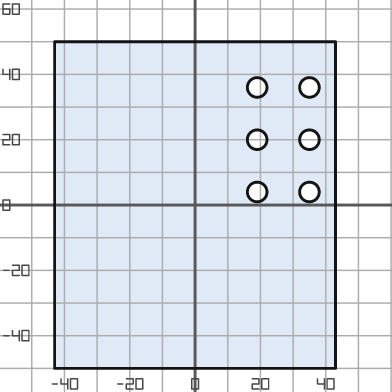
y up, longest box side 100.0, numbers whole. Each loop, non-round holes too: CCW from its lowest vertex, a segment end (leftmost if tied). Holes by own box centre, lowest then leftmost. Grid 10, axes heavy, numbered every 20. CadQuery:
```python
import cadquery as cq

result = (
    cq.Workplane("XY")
    .moveTo(-43.0, -50.0)
    .lineTo(43.0, -50.0)
    .lineTo(43.0, 50.0)
    .lineTo(-43.0, 50.0)
    .close()
    .moveTo(19.0, 4.0)
    .circle(3.0)
    .moveTo(35.0, 4.0)
    .circle(3.0)
    .moveTo(19.0, 20.0)
    .circle(3.0)
    .moveTo(35.0, 20.0)
    .circle(3.0)
    .moveTo(19.0, 36.0)
    .circle(3.0)
    .moveTo(35.0, 36.0)
    .circle(3.0)
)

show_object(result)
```